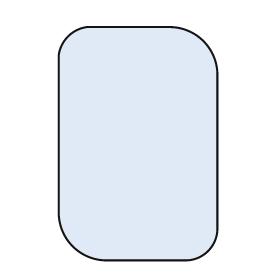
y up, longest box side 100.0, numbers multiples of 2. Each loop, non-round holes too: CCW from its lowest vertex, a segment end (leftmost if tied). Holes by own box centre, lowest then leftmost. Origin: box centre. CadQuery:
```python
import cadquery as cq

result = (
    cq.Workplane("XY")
    .moveTo(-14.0, -50.0)
    .lineTo(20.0, -50.0)
    .threePointArc((30.0, -46.0), (34.0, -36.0))
    .lineTo(34.0, 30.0)
    .threePointArc((28.0, 44.0), (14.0, 50.0))
    .lineTo(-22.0, 50.0)
    .threePointArc((-30.0, 46.0), (-34.0, 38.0))
    .lineTo(-34.0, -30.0)
    .threePointArc((-28.0, -44.0), (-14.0, -50.0))
    .close()
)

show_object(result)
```